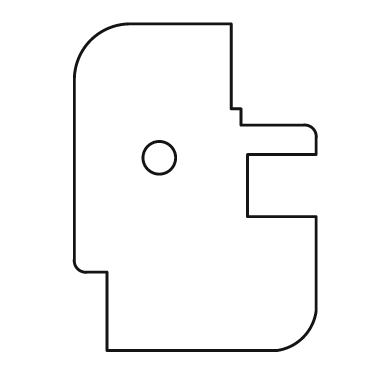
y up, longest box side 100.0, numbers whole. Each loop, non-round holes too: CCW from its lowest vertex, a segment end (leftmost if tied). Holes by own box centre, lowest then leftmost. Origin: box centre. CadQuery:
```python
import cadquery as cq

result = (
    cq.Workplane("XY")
    .moveTo(-27.0, -50.0)
    .lineTo(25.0, -50.0)
    .threePointArc((33.0, -46.0), (37.0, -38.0))
    .lineTo(37.0, -9.0)
    .lineTo(16.0, -9.0)
    .lineTo(16.0, 10.0)
    .lineTo(37.0, 10.0)
    .lineTo(37.0, 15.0)
    .threePointArc((36.0, 18.0), (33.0, 19.0))
    .lineTo(14.0, 19.0)
    .lineTo(14.0, 24.0)
    .lineTo(11.0, 24.0)
    .lineTo(11.0, 50.0)
    .lineTo(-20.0, 50.0)
    .threePointArc((-32.0, 45.0), (-37.0, 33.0))
    .lineTo(-37.0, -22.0)
    .threePointArc((-36.0, -25.0), (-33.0, -26.0))
    .lineTo(-27.0, -26.0)
    .close()
    .moveTo(-11.0, 9.0)
    .circle(5.0)
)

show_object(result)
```